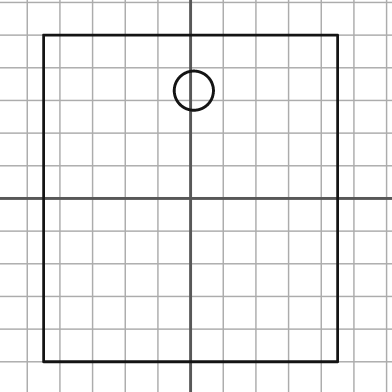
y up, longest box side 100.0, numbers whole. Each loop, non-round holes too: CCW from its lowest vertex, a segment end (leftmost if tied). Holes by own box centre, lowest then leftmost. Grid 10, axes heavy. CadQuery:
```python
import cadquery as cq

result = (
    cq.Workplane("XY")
    .moveTo(-45.0, -50.0)
    .lineTo(45.0, -50.0)
    .lineTo(45.0, 50.0)
    .lineTo(-45.0, 50.0)
    .close()
    .moveTo(1.0, 33.0)
    .circle(6.0)
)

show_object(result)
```